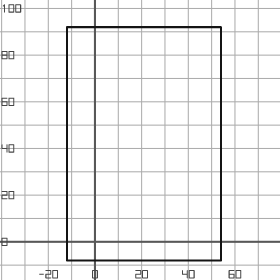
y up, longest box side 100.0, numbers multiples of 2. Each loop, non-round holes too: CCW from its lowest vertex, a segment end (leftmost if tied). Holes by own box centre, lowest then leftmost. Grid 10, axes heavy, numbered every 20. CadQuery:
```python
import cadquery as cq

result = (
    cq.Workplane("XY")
    .moveTo(-12.0, -8.0)
    .lineTo(54.0, -8.0)
    .lineTo(54.0, 92.0)
    .lineTo(-12.0, 92.0)
    .close()
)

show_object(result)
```